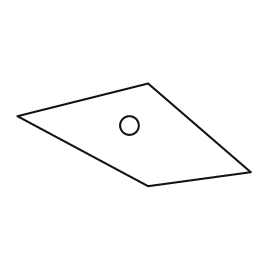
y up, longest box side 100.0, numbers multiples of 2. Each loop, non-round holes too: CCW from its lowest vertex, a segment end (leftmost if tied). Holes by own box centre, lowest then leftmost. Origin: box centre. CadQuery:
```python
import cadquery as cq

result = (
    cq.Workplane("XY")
    .moveTo(6.0, -22.0)
    .lineTo(50.0, -16.0)
    .lineTo(6.0, 22.0)
    .lineTo(-50.0, 8.0)
    .close()
    .moveTo(-2.0, 4.0)
    .circle(4.0)
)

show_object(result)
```